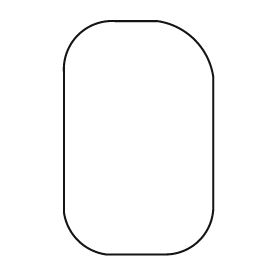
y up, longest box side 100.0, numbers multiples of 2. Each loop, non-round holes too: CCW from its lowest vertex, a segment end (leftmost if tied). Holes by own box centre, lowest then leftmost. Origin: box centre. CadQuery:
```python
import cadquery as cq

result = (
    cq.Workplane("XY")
    .moveTo(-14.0, -50.0)
    .lineTo(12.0, -50.0)
    .threePointArc((26.0, -44.0), (32.0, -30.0))
    .lineTo(32.0, 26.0)
    .threePointArc((24.0, 42.0), (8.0, 50.0))
    .lineTo(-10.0, 50.0)
    .threePointArc((-26.0, 44.0), (-32.0, 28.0))
    .lineTo(-32.0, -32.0)
    .threePointArc((-26.0, -44.0), (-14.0, -50.0))
    .close()
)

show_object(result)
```